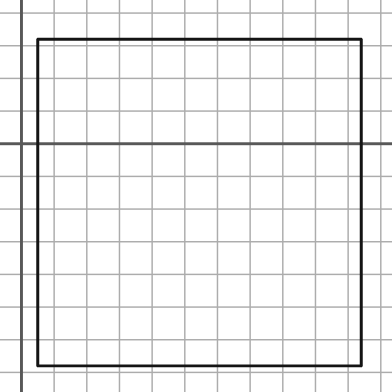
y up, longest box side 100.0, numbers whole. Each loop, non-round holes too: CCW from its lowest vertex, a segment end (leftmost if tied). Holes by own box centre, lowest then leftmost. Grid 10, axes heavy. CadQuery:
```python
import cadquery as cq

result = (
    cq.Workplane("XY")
    .moveTo(5.0, -68.0)
    .lineTo(104.0, -68.0)
    .lineTo(104.0, 32.0)
    .lineTo(5.0, 32.0)
    .close()
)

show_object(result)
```